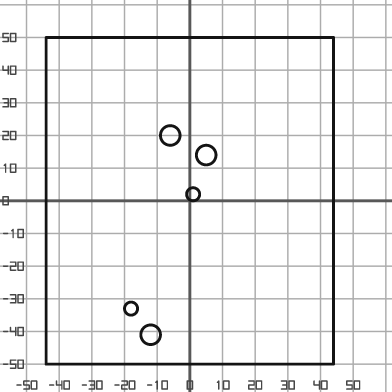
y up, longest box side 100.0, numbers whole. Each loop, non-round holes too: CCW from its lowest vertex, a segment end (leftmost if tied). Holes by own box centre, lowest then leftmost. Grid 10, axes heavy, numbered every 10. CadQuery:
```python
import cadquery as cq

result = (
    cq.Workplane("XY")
    .moveTo(-44.0, -50.0)
    .lineTo(44.0, -50.0)
    .lineTo(44.0, 50.0)
    .lineTo(-44.0, 50.0)
    .close()
    .moveTo(-12.0, -41.0)
    .circle(3.0)
    .moveTo(-18.0, -33.0)
    .circle(2.0)
    .moveTo(1.0, 2.0)
    .circle(2.0)
    .moveTo(5.0, 14.0)
    .circle(3.0)
    .moveTo(-6.0, 20.0)
    .circle(3.0)
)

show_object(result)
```